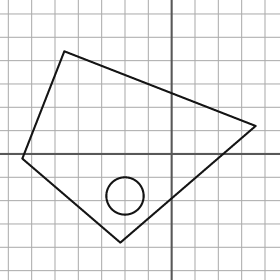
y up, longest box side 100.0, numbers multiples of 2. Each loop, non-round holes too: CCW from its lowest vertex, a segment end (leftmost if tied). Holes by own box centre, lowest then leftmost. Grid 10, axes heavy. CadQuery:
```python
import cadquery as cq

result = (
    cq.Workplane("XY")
    .moveTo(-22.0, -38.0)
    .lineTo(36.0, 12.0)
    .lineTo(-46.0, 44.0)
    .lineTo(-64.0, -2.0)
    .close()
    .moveTo(-20.0, -18.0)
    .circle(8.0)
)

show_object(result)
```